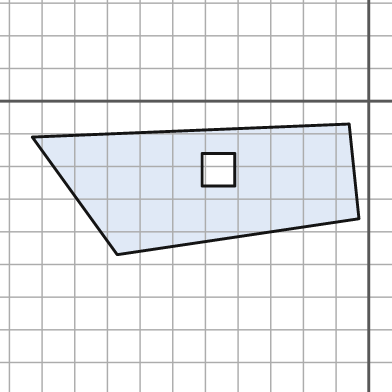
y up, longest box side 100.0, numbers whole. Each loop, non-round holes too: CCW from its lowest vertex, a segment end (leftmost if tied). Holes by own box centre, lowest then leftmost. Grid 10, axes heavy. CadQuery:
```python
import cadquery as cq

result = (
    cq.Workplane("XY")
    .moveTo(-77.0, -47.0)
    .lineTo(-3.0, -36.0)
    .lineTo(-6.0, -7.0)
    .lineTo(-103.0, -11.0)
    .close()
    .moveTo(-51.0, -26.0)
    .lineTo(-41.0, -26.0)
    .lineTo(-41.0, -16.0)
    .lineTo(-51.0, -16.0)
    .close()
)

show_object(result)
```